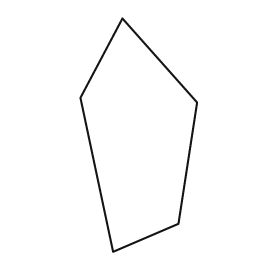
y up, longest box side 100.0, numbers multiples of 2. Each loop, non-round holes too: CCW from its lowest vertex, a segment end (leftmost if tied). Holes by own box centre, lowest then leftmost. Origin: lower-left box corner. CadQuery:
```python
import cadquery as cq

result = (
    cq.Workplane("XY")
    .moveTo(14.0, 0.0)
    .lineTo(42.0, 12.0)
    .lineTo(50.0, 64.0)
    .lineTo(18.0, 100.0)
    .lineTo(0.0, 66.0)
    .close()
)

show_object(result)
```